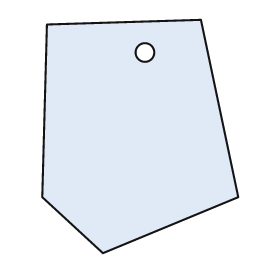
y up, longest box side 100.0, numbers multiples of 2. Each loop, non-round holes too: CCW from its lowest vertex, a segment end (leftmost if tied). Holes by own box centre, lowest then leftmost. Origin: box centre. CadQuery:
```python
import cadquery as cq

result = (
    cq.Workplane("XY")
    .moveTo(-16.0, -50.0)
    .lineTo(42.0, -26.0)
    .lineTo(26.0, 50.0)
    .lineTo(-40.0, 48.0)
    .lineTo(-42.0, -26.0)
    .close()
    .moveTo(2.0, 36.0)
    .circle(4.0)
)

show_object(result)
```